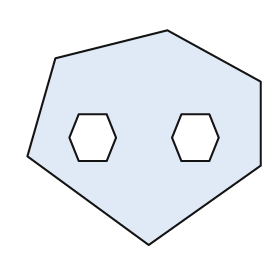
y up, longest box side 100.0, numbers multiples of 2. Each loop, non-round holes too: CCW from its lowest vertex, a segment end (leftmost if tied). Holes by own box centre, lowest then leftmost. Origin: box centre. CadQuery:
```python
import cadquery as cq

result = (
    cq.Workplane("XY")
    .moveTo(2.0, -46.0)
    .lineTo(50.0, -12.0)
    .lineTo(50.0, 24.0)
    .lineTo(10.0, 46.0)
    .lineTo(-38.0, 34.0)
    .lineTo(-50.0, -8.0)
    .close()
    .moveTo(-28.0, -10.0)
    .lineTo(-16.0, -10.0)
    .lineTo(-12.0, 0.0)
    .lineTo(-16.0, 10.0)
    .lineTo(-28.0, 10.0)
    .lineTo(-32.0, 0.0)
    .close()
    .moveTo(16.0, -10.0)
    .lineTo(28.0, -10.0)
    .lineTo(32.0, 0.0)
    .lineTo(28.0, 10.0)
    .lineTo(16.0, 10.0)
    .lineTo(12.0, 0.0)
    .close()
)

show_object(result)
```